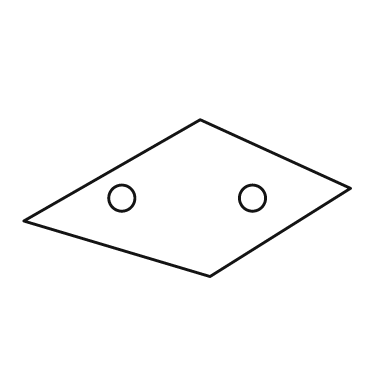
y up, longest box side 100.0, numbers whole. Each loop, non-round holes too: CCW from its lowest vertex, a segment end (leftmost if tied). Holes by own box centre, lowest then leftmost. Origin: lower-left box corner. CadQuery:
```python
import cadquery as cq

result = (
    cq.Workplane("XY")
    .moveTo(57.0, 0.0)
    .lineTo(100.0, 27.0)
    .lineTo(54.0, 48.0)
    .lineTo(0.0, 17.0)
    .close()
    .moveTo(30.0, 24.0)
    .circle(4.0)
    .moveTo(70.0, 24.0)
    .circle(4.0)
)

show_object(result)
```